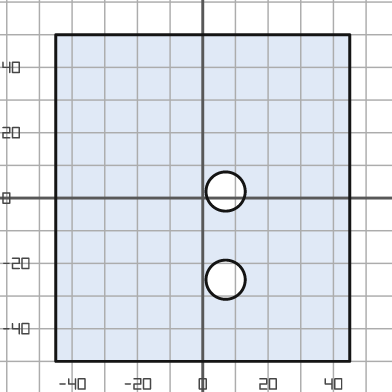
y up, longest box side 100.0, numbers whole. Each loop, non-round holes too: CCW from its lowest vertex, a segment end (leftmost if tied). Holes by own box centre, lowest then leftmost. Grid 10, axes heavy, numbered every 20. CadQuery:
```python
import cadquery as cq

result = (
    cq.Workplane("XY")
    .moveTo(-45.0, -50.0)
    .lineTo(45.0, -50.0)
    .lineTo(45.0, 50.0)
    .lineTo(-45.0, 50.0)
    .close()
    .moveTo(7.0, -25.0)
    .circle(6.0)
    .moveTo(7.0, 2.0)
    .circle(6.0)
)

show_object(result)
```